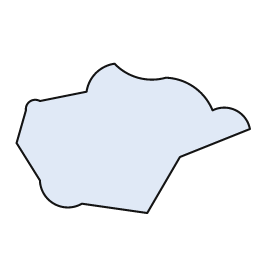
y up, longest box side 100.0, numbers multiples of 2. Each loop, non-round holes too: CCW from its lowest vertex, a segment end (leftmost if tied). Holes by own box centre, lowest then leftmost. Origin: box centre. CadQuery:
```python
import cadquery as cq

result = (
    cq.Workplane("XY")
    .moveTo(6.0, -32.0)
    .lineTo(20.0, -8.0)
    .lineTo(50.0, 4.0)
    .threePointArc((44.0, 12.0), (34.0, 12.0))
    .threePointArc((26.0, 22.0), (14.0, 26.0))
    .threePointArc((2.0, 26.0), (-8.0, 32.0))
    .threePointArc((-16.0, 28.0), (-20.0, 20.0))
    .lineTo(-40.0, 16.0)
    .threePointArc((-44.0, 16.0), (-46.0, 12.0))
    .lineTo(-50.0, -2.0)
    .lineTo(-40.0, -18.0)
    .threePointArc((-34.0, -28.0), (-22.0, -28.0))
    .close()
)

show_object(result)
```